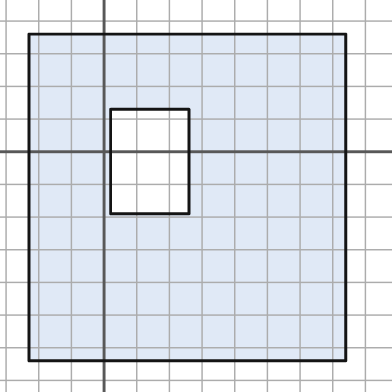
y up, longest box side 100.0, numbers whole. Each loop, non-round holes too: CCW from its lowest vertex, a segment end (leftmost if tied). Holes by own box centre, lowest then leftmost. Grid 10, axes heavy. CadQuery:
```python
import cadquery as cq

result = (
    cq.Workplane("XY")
    .moveTo(-23.0, -64.0)
    .lineTo(74.0, -64.0)
    .lineTo(74.0, 36.0)
    .lineTo(-23.0, 36.0)
    .close()
    .moveTo(2.0, -19.0)
    .lineTo(26.0, -19.0)
    .lineTo(26.0, 13.0)
    .lineTo(2.0, 13.0)
    .close()
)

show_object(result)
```